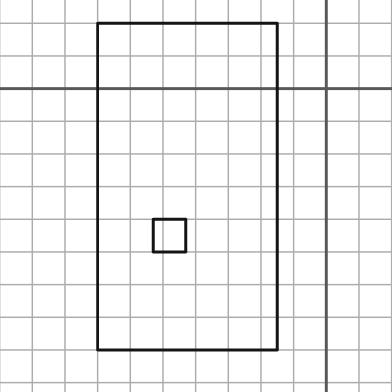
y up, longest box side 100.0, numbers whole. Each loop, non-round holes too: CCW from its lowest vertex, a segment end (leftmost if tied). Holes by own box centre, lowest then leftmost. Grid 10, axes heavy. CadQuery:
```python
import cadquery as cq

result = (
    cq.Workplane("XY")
    .moveTo(-70.0, -80.0)
    .lineTo(-15.0, -80.0)
    .lineTo(-15.0, 20.0)
    .lineTo(-70.0, 20.0)
    .close()
    .moveTo(-53.0, -50.0)
    .lineTo(-43.0, -50.0)
    .lineTo(-43.0, -40.0)
    .lineTo(-53.0, -40.0)
    .close()
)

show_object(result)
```